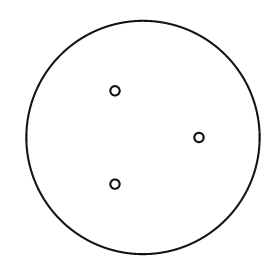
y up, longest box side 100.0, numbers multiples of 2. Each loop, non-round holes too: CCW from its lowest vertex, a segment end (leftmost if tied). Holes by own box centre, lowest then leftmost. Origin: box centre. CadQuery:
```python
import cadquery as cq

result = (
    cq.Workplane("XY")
    .moveTo(0.0, 0.0)
    .circle(50.0)
    .moveTo(-12.0, -20.0)
    .circle(2.0)
    .moveTo(24.0, 0.0)
    .circle(2.0)
    .moveTo(-12.0, 20.0)
    .circle(2.0)
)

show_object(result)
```